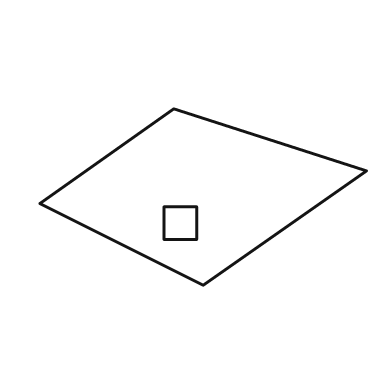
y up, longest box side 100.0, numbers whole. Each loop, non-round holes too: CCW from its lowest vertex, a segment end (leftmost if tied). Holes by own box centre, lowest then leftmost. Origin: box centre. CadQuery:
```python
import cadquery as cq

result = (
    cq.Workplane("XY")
    .moveTo(0.0, -27.0)
    .lineTo(50.0, 8.0)
    .lineTo(-9.0, 27.0)
    .lineTo(-50.0, -2.0)
    .close()
    .moveTo(-12.0, -13.0)
    .lineTo(-2.0, -13.0)
    .lineTo(-2.0, -3.0)
    .lineTo(-12.0, -3.0)
    .close()
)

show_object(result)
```